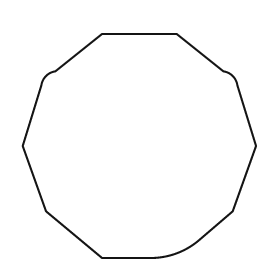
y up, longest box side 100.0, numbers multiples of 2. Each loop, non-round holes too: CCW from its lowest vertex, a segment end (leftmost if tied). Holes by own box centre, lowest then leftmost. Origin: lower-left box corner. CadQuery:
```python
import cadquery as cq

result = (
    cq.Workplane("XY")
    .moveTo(34.0, 0.0)
    .lineTo(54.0, 0.0)
    .threePointArc((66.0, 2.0), (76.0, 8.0))
    .lineTo(90.0, 20.0)
    .lineTo(100.0, 48.0)
    .lineTo(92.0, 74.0)
    .threePointArc((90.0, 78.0), (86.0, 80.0))
    .lineTo(66.0, 96.0)
    .lineTo(34.0, 96.0)
    .lineTo(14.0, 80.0)
    .threePointArc((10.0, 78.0), (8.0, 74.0))
    .lineTo(0.0, 48.0)
    .lineTo(10.0, 20.0)
    .close()
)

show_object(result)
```